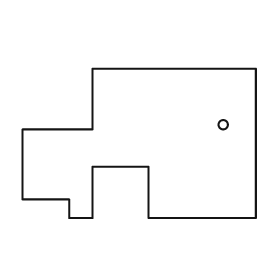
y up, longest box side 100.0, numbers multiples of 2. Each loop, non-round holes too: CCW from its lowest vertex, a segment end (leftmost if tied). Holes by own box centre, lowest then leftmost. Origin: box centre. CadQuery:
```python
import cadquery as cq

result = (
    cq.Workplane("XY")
    .moveTo(-30.0, -32.0)
    .lineTo(-20.0, -32.0)
    .lineTo(-20.0, -10.0)
    .lineTo(4.0, -10.0)
    .lineTo(4.0, -32.0)
    .lineTo(50.0, -32.0)
    .lineTo(50.0, 32.0)
    .lineTo(-20.0, 32.0)
    .lineTo(-20.0, 6.0)
    .lineTo(-50.0, 6.0)
    .lineTo(-50.0, -24.0)
    .lineTo(-30.0, -24.0)
    .close()
    .moveTo(36.0, 8.0)
    .circle(2.0)
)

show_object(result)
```